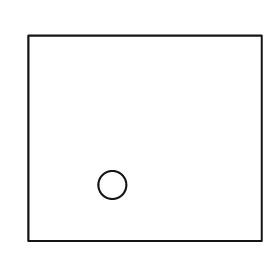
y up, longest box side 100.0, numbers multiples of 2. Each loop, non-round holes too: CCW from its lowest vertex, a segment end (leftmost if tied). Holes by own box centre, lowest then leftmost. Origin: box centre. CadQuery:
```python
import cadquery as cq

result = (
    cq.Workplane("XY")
    .moveTo(-50.0, -44.0)
    .lineTo(50.0, -44.0)
    .lineTo(50.0, 44.0)
    .lineTo(-50.0, 44.0)
    .close()
    .moveTo(-14.0, -20.0)
    .circle(6.0)
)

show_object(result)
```